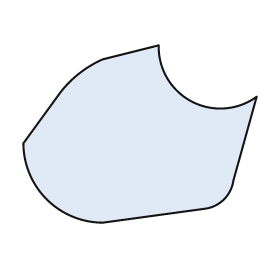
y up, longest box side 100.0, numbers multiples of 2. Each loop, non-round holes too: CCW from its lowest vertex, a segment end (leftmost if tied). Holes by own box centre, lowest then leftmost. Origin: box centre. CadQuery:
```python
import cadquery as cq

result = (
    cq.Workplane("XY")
    .moveTo(-16.0, -38.0)
    .lineTo(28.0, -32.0)
    .threePointArc((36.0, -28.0), (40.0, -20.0))
    .lineTo(50.0, 16.0)
    .threePointArc((22.0, 14.0), (8.0, 38.0))
    .lineTo(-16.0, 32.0)
    .threePointArc((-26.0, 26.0), (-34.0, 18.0))
    .lineTo(-50.0, -4.0)
    .threePointArc((-40.0, -28.0), (-16.0, -38.0))
    .close()
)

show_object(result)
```